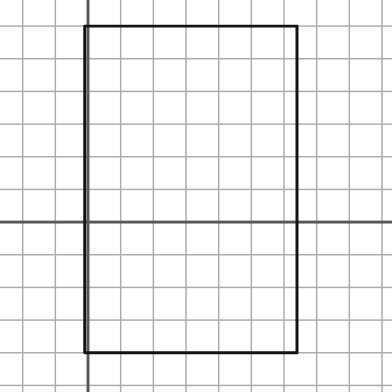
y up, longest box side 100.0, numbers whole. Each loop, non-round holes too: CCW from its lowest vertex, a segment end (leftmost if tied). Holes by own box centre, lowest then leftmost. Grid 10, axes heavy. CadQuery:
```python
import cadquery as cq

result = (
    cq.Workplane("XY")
    .moveTo(-1.0, -40.0)
    .lineTo(64.0, -40.0)
    .lineTo(64.0, 60.0)
    .lineTo(-1.0, 60.0)
    .close()
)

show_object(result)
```